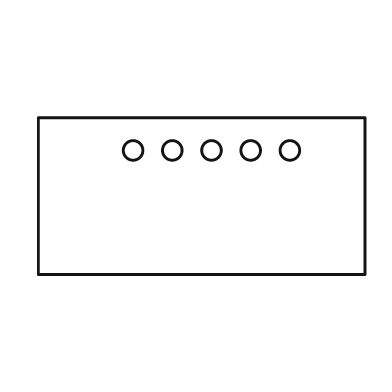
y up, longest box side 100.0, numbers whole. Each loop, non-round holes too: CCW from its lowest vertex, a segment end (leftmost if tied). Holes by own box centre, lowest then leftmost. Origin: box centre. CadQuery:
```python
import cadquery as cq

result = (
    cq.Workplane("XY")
    .moveTo(-50.0, -24.0)
    .lineTo(50.0, -24.0)
    .lineTo(50.0, 24.0)
    .lineTo(-50.0, 24.0)
    .close()
    .moveTo(-21.0, 14.0)
    .circle(3.0)
    .moveTo(-9.0, 14.0)
    .circle(3.0)
    .moveTo(3.0, 14.0)
    .circle(3.0)
    .moveTo(15.0, 14.0)
    .circle(3.0)
    .moveTo(27.0, 14.0)
    .circle(3.0)
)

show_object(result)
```